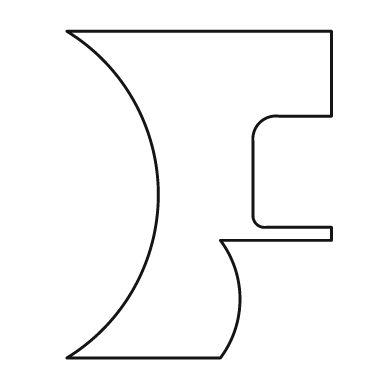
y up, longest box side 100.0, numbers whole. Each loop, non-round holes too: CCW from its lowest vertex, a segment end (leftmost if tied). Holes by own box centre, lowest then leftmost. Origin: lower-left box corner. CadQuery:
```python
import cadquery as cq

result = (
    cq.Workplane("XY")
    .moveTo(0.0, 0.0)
    .lineTo(47.0, 0.0)
    .threePointArc((53.0, 18.0), (47.0, 36.0))
    .lineTo(81.0, 36.0)
    .lineTo(81.0, 40.0)
    .lineTo(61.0, 40.0)
    .threePointArc((58.0, 41.0), (57.0, 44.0))
    .lineTo(57.0, 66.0)
    .threePointArc((59.0, 72.0), (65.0, 74.0))
    .lineTo(81.0, 74.0)
    .lineTo(81.0, 100.0)
    .lineTo(0.0, 100.0)
    .threePointArc((28.0, 50.0), (0.0, 0.0))
    .close()
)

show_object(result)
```